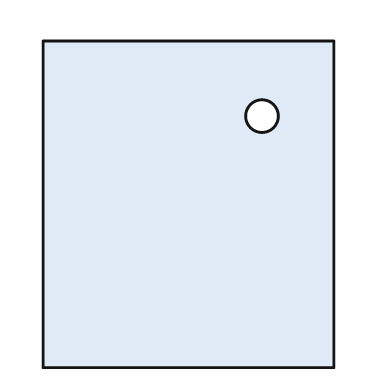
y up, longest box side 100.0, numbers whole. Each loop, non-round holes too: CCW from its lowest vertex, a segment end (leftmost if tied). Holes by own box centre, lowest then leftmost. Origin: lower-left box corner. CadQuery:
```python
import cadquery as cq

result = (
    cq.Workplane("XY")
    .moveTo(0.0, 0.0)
    .lineTo(89.0, 0.0)
    .lineTo(89.0, 100.0)
    .lineTo(0.0, 100.0)
    .close()
    .moveTo(67.0, 77.0)
    .circle(5.0)
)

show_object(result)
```